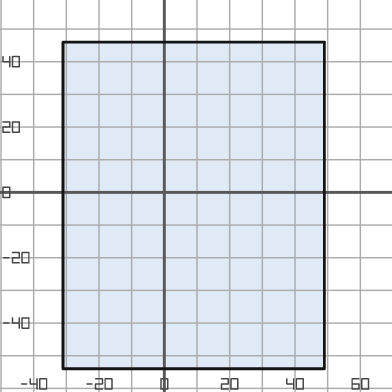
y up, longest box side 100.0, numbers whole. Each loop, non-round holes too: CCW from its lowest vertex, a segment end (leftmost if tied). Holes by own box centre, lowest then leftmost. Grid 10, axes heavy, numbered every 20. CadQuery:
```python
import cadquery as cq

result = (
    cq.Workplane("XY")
    .moveTo(-31.0, -54.0)
    .lineTo(49.0, -54.0)
    .lineTo(49.0, 46.0)
    .lineTo(-31.0, 46.0)
    .close()
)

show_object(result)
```